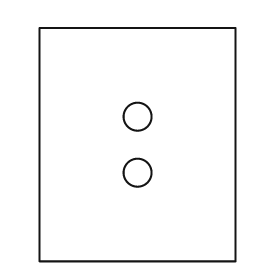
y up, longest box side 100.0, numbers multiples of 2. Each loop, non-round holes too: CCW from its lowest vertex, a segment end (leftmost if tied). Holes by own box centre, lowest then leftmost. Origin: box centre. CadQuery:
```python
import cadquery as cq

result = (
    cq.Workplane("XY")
    .moveTo(-42.0, -50.0)
    .lineTo(42.0, -50.0)
    .lineTo(42.0, 50.0)
    .lineTo(-42.0, 50.0)
    .close()
    .moveTo(0.0, -12.0)
    .circle(6.0)
    .moveTo(0.0, 12.0)
    .circle(6.0)
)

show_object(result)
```